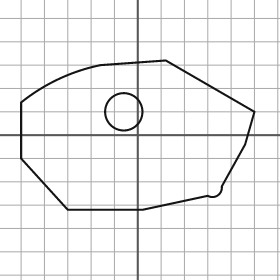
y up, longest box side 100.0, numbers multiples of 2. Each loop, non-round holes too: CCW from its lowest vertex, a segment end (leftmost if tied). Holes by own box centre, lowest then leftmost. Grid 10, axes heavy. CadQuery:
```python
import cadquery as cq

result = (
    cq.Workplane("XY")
    .moveTo(-30.0, -32.0)
    .lineTo(2.0, -32.0)
    .lineTo(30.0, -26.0)
    .threePointArc((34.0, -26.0), (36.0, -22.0))
    .lineTo(46.0, -4.0)
    .lineTo(50.0, 10.0)
    .lineTo(12.0, 32.0)
    .lineTo(-16.0, 30.0)
    .threePointArc((-34.0, 24.0), (-50.0, 14.0))
    .lineTo(-50.0, -10.0)
    .close()
    .moveTo(-6.0, 10.0)
    .circle(8.0)
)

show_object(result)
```